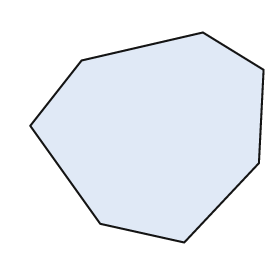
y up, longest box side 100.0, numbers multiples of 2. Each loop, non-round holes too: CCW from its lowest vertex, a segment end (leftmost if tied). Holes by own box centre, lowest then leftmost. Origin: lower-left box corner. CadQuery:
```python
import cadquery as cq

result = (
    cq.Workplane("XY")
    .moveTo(66.0, 0.0)
    .lineTo(98.0, 34.0)
    .lineTo(100.0, 74.0)
    .lineTo(74.0, 90.0)
    .lineTo(22.0, 78.0)
    .lineTo(0.0, 50.0)
    .lineTo(30.0, 8.0)
    .close()
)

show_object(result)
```